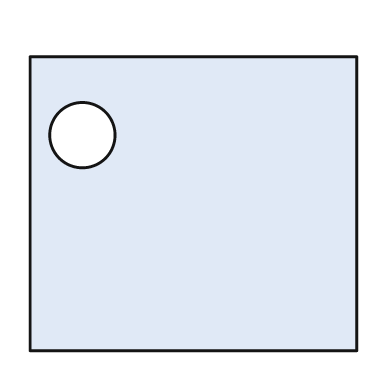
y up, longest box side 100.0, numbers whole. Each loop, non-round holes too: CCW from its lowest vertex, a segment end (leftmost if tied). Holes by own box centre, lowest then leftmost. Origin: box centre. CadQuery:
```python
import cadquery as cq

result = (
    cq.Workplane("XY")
    .moveTo(-50.0, -45.0)
    .lineTo(50.0, -45.0)
    .lineTo(50.0, 45.0)
    .lineTo(-50.0, 45.0)
    .close()
    .moveTo(-34.0, 21.0)
    .circle(10.0)
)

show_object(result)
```